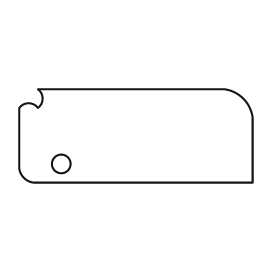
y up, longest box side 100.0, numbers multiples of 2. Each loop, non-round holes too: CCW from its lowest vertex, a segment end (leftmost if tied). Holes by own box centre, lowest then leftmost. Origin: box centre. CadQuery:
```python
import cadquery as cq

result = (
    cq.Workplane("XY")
    .moveTo(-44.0, -20.0)
    .lineTo(50.0, -20.0)
    .lineTo(50.0, 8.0)
    .threePointArc((46.0, 16.0), (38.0, 20.0))
    .lineTo(-42.0, 20.0)
    .threePointArc((-40.0, 16.0), (-42.0, 12.0))
    .threePointArc((-46.0, 14.0), (-50.0, 12.0))
    .lineTo(-50.0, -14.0)
    .threePointArc((-48.0, -18.0), (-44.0, -20.0))
    .close()
    .moveTo(-32.0, -12.0)
    .circle(4.0)
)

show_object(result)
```